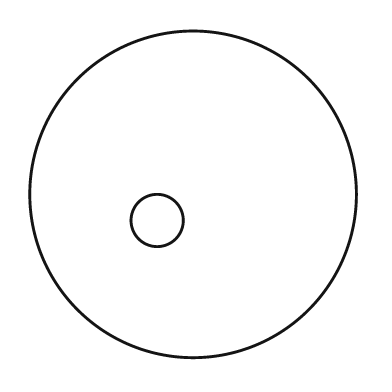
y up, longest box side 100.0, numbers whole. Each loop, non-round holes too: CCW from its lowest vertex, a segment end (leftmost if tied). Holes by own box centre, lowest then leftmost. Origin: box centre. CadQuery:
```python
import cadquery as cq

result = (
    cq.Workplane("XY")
    .moveTo(0.0, 0.0)
    .circle(50.0)
    .moveTo(-11.0, -8.0)
    .circle(8.0)
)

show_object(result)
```